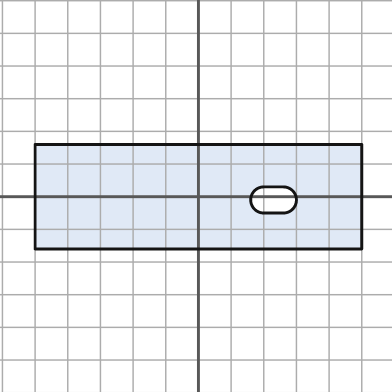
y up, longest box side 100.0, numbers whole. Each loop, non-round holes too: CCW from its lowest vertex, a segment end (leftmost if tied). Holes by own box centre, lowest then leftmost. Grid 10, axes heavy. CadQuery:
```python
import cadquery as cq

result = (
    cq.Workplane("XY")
    .moveTo(-50.0, -16.0)
    .lineTo(50.0, -16.0)
    .lineTo(50.0, 16.0)
    .lineTo(-50.0, 16.0)
    .close()
    .moveTo(20.0, -5.0)
    .lineTo(26.0, -5.0)
    .threePointArc((30.0, -1.0), (26.0, 3.0))
    .lineTo(20.0, 3.0)
    .threePointArc((16.0, -1.0), (20.0, -5.0))
    .close()
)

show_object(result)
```